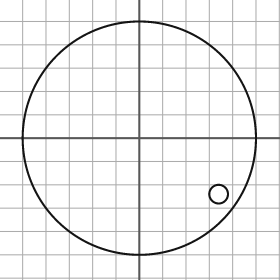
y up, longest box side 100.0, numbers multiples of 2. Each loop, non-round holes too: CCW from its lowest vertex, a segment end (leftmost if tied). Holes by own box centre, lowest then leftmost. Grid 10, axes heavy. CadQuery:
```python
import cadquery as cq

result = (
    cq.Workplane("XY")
    .moveTo(0.0, 0.0)
    .circle(50.0)
    .moveTo(34.0, -24.0)
    .circle(4.0)
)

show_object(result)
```